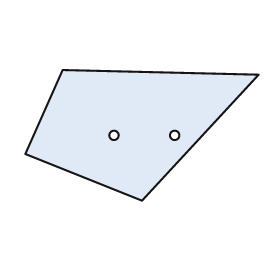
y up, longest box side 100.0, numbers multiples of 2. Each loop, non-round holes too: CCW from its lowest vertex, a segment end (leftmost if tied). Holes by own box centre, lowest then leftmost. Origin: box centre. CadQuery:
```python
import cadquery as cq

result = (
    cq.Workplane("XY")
    .moveTo(0.0, -28.0)
    .lineTo(50.0, 26.0)
    .lineTo(-34.0, 28.0)
    .lineTo(-50.0, -8.0)
    .close()
    .moveTo(-12.0, 0.0)
    .circle(2.0)
    .moveTo(14.0, 0.0)
    .circle(2.0)
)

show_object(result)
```